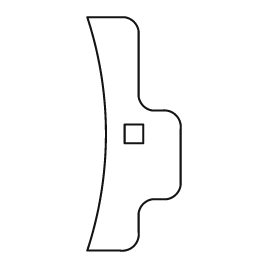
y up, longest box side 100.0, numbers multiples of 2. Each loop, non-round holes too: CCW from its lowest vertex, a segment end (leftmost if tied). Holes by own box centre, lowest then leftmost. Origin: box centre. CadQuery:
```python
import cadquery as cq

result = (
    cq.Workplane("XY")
    .moveTo(-20.0, -50.0)
    .lineTo(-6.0, -50.0)
    .threePointArc((0.0, -48.0), (2.0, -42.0))
    .lineTo(2.0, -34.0)
    .threePointArc((4.0, -30.0), (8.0, -28.0))
    .lineTo(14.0, -28.0)
    .threePointArc((18.0, -26.0), (20.0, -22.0))
    .lineTo(20.0, 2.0)
    .threePointArc((18.0, 8.0), (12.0, 10.0))
    .lineTo(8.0, 10.0)
    .threePointArc((4.0, 12.0), (2.0, 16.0))
    .lineTo(2.0, 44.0)
    .threePointArc((0.0, 48.0), (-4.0, 50.0))
    .lineTo(-20.0, 50.0)
    .threePointArc((-12.0, 0.0), (-20.0, -50.0))
    .close()
    .moveTo(-4.0, -4.0)
    .lineTo(4.0, -4.0)
    .lineTo(4.0, 4.0)
    .lineTo(-4.0, 4.0)
    .close()
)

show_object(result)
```